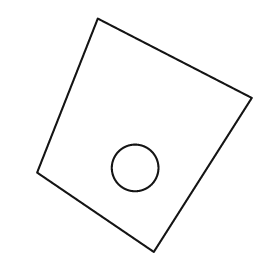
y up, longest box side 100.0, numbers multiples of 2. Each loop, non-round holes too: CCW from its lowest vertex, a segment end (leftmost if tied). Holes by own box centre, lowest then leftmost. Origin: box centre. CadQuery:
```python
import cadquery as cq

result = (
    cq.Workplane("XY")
    .moveTo(4.0, -50.0)
    .lineTo(46.0, 16.0)
    .lineTo(-20.0, 50.0)
    .lineTo(-46.0, -16.0)
    .close()
    .moveTo(-4.0, -14.0)
    .circle(10.0)
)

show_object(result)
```